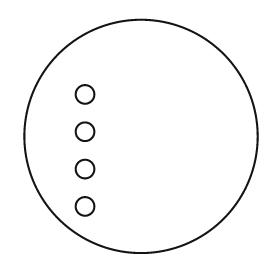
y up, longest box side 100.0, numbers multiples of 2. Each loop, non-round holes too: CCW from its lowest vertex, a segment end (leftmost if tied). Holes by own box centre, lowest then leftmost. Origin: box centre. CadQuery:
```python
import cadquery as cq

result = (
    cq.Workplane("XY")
    .moveTo(0.0, 0.0)
    .circle(50.0)
    .moveTo(-24.0, -30.0)
    .circle(4.0)
    .moveTo(-24.0, -14.0)
    .circle(4.0)
    .moveTo(-24.0, 2.0)
    .circle(4.0)
    .moveTo(-24.0, 18.0)
    .circle(4.0)
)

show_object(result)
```